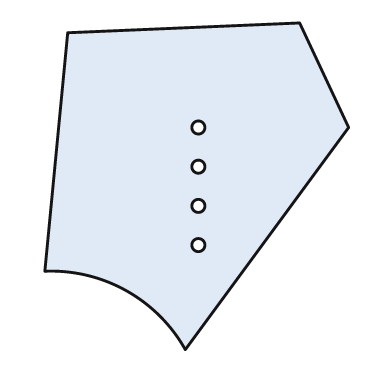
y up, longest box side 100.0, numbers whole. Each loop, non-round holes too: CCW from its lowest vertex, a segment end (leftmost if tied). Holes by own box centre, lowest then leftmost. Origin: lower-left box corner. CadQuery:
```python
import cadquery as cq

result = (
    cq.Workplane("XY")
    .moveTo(43.0, 0.0)
    .lineTo(93.0, 68.0)
    .lineTo(78.0, 100.0)
    .lineTo(7.0, 97.0)
    .lineTo(0.0, 24.0)
    .threePointArc((25.0, 18.0), (43.0, 0.0))
    .close()
    .moveTo(47.0, 32.0)
    .circle(2.0)
    .moveTo(47.0, 44.0)
    .circle(2.0)
    .moveTo(47.0, 56.0)
    .circle(2.0)
    .moveTo(47.0, 68.0)
    .circle(2.0)
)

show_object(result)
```